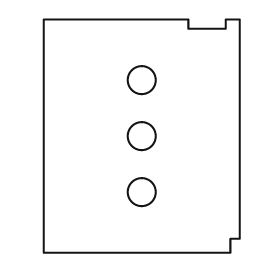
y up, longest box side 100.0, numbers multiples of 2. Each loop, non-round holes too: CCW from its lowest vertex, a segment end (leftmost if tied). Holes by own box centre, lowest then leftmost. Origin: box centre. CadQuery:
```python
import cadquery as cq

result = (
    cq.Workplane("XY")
    .moveTo(-42.0, -50.0)
    .lineTo(38.0, -50.0)
    .lineTo(38.0, -44.0)
    .lineTo(42.0, -44.0)
    .lineTo(42.0, 50.0)
    .lineTo(36.0, 50.0)
    .lineTo(36.0, 46.0)
    .lineTo(20.0, 46.0)
    .lineTo(20.0, 50.0)
    .lineTo(-42.0, 50.0)
    .close()
    .moveTo(0.0, -24.0)
    .circle(6.0)
    .moveTo(0.0, 0.0)
    .circle(6.0)
    .moveTo(0.0, 24.0)
    .circle(6.0)
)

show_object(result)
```